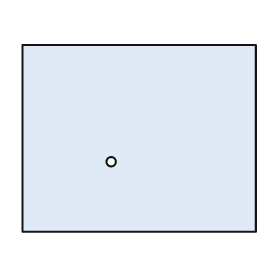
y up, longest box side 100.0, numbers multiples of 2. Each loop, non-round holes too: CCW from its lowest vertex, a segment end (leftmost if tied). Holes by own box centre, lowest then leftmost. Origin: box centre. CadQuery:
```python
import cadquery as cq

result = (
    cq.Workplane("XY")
    .moveTo(-50.0, -40.0)
    .lineTo(50.0, -40.0)
    .lineTo(50.0, 40.0)
    .lineTo(-50.0, 40.0)
    .close()
    .moveTo(-12.0, -10.0)
    .circle(2.0)
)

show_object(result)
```